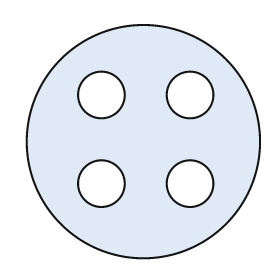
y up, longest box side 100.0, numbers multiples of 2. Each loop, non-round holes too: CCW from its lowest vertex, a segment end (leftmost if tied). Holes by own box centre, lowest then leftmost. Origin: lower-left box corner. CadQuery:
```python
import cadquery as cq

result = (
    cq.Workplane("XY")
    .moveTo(50.0, 50.0)
    .circle(50.0)
    .moveTo(32.0, 32.0)
    .circle(10.0)
    .moveTo(70.0, 32.0)
    .circle(10.0)
    .moveTo(32.0, 70.0)
    .circle(10.0)
    .moveTo(70.0, 70.0)
    .circle(10.0)
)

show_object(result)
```